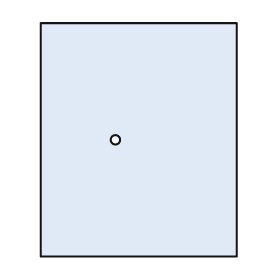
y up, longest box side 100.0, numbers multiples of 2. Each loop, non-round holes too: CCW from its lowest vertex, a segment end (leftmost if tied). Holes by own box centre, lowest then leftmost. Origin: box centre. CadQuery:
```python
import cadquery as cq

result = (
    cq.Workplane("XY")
    .moveTo(-42.0, -50.0)
    .lineTo(42.0, -50.0)
    .lineTo(42.0, 50.0)
    .lineTo(-42.0, 50.0)
    .close()
    .moveTo(-10.0, 0.0)
    .circle(2.0)
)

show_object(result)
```